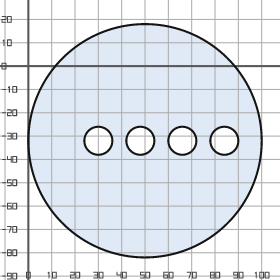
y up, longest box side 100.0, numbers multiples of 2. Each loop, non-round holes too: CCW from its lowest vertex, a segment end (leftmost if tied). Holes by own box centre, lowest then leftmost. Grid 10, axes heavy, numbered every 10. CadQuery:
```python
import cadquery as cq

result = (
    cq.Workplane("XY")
    .moveTo(50.0, -32.0)
    .circle(50.0)
    .moveTo(30.0, -32.0)
    .circle(6.0)
    .moveTo(48.0, -32.0)
    .circle(6.0)
    .moveTo(66.0, -32.0)
    .circle(6.0)
    .moveTo(84.0, -32.0)
    .circle(6.0)
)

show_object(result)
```